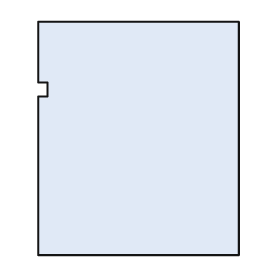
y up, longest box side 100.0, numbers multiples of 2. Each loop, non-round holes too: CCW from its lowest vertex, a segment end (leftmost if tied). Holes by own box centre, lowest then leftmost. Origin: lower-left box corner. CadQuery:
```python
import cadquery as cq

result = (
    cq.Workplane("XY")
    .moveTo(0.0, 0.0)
    .lineTo(86.0, 0.0)
    .lineTo(86.0, 100.0)
    .lineTo(0.0, 100.0)
    .lineTo(0.0, 74.0)
    .lineTo(4.0, 74.0)
    .lineTo(4.0, 68.0)
    .lineTo(0.0, 68.0)
    .close()
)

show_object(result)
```